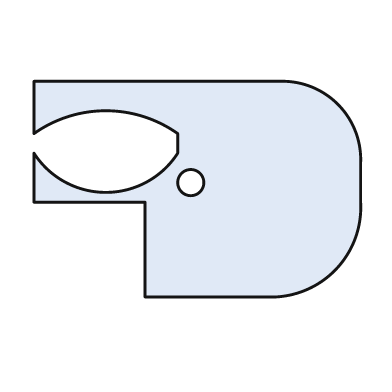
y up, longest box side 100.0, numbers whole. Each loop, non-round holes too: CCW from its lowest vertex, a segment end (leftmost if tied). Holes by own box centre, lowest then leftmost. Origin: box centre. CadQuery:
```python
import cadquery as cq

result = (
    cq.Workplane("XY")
    .moveTo(-16.0, -33.0)
    .lineTo(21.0, -33.0)
    .threePointArc((42.0, -25.0), (50.0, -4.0))
    .lineTo(50.0, 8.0)
    .threePointArc((43.0, 26.0), (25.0, 33.0))
    .lineTo(-50.0, 33.0)
    .lineTo(-50.0, 17.0)
    .threePointArc((-28.0, 24.0), (-6.0, 17.0))
    .lineTo(-6.0, 11.0)
    .threePointArc((-28.0, -1.0), (-50.0, 11.0))
    .lineTo(-50.0, -4.0)
    .lineTo(-16.0, -4.0)
    .close()
    .moveTo(-2.0, 2.0)
    .circle(4.0)
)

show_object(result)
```